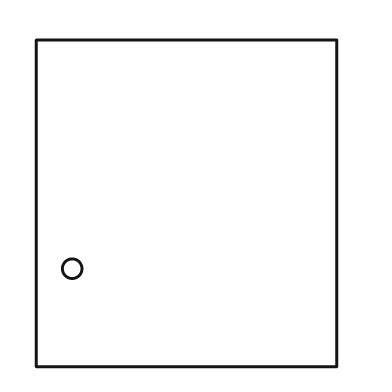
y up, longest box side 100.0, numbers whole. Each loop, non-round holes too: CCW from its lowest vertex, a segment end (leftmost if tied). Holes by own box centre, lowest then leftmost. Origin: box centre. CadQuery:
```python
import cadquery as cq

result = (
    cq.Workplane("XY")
    .moveTo(-46.0, -50.0)
    .lineTo(46.0, -50.0)
    .lineTo(46.0, 50.0)
    .lineTo(-46.0, 50.0)
    .close()
    .moveTo(-35.0, -20.0)
    .circle(3.0)
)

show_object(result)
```